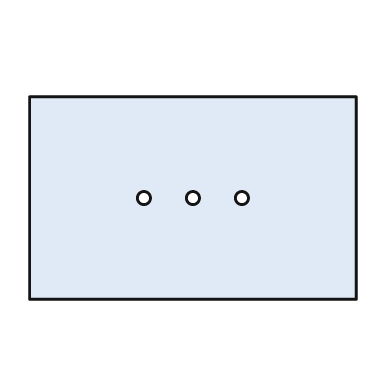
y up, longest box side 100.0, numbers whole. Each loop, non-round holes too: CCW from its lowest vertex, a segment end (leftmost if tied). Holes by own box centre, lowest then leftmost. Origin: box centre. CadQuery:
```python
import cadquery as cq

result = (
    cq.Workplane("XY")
    .moveTo(-50.0, -31.0)
    .lineTo(50.0, -31.0)
    .lineTo(50.0, 31.0)
    .lineTo(-50.0, 31.0)
    .close()
    .moveTo(-15.0, 0.0)
    .circle(2.0)
    .moveTo(0.0, 0.0)
    .circle(2.0)
    .moveTo(15.0, 0.0)
    .circle(2.0)
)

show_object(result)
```